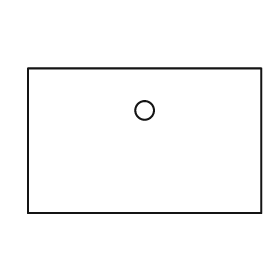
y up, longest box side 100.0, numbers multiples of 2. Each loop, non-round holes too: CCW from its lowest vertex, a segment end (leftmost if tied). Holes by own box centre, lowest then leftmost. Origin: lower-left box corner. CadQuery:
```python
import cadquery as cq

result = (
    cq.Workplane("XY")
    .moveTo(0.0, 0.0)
    .lineTo(100.0, 0.0)
    .lineTo(100.0, 62.0)
    .lineTo(0.0, 62.0)
    .close()
    .moveTo(50.0, 44.0)
    .circle(4.0)
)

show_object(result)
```